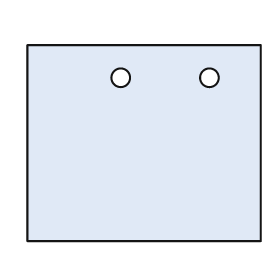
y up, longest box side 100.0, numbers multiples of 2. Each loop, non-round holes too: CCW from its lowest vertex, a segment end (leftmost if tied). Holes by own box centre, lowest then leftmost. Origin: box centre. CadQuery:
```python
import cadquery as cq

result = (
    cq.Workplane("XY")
    .moveTo(-50.0, -42.0)
    .lineTo(50.0, -42.0)
    .lineTo(50.0, 42.0)
    .lineTo(-50.0, 42.0)
    .close()
    .moveTo(-10.0, 28.0)
    .circle(4.0)
    .moveTo(28.0, 28.0)
    .circle(4.0)
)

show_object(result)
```